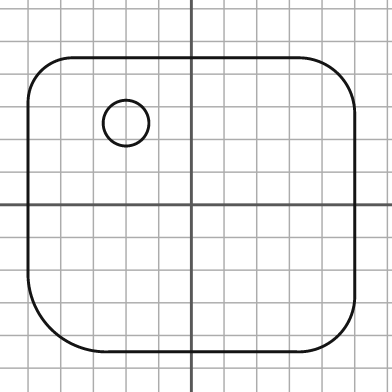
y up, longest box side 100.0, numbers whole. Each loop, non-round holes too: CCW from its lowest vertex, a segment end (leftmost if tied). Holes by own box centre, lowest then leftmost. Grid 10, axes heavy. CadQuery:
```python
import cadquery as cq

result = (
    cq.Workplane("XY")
    .moveTo(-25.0, -45.0)
    .lineTo(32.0, -45.0)
    .threePointArc((45.0, -40.0), (50.0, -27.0))
    .lineTo(50.0, 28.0)
    .threePointArc((45.0, 40.0), (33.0, 45.0))
    .lineTo(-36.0, 45.0)
    .threePointArc((-46.0, 41.0), (-50.0, 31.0))
    .lineTo(-50.0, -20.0)
    .threePointArc((-43.0, -38.0), (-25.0, -45.0))
    .close()
    .moveTo(-20.0, 25.0)
    .circle(7.0)
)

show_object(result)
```